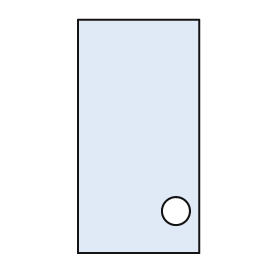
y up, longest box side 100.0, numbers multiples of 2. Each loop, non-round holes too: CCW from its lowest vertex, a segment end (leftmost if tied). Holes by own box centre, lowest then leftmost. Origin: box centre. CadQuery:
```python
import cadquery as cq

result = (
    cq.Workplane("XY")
    .moveTo(-26.0, -50.0)
    .lineTo(26.0, -50.0)
    .lineTo(26.0, 50.0)
    .lineTo(-26.0, 50.0)
    .close()
    .moveTo(16.0, -32.0)
    .circle(6.0)
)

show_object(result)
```